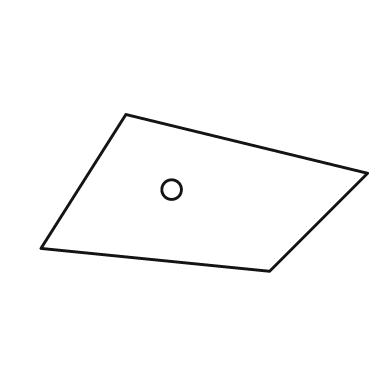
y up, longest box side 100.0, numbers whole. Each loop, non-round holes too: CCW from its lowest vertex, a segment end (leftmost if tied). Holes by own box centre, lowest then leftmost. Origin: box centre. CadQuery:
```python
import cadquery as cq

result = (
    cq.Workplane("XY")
    .moveTo(20.0, -24.0)
    .lineTo(50.0, 6.0)
    .lineTo(-24.0, 24.0)
    .lineTo(-50.0, -17.0)
    .close()
    .moveTo(-10.0, 1.0)
    .circle(3.0)
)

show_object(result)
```